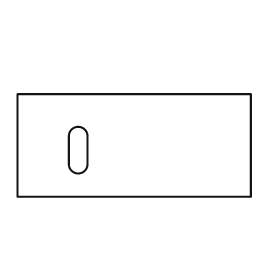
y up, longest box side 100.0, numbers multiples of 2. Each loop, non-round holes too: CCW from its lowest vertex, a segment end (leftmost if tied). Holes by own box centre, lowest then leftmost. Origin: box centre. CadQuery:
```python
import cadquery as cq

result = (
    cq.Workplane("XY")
    .moveTo(-50.0, -22.0)
    .lineTo(50.0, -22.0)
    .lineTo(50.0, 22.0)
    .lineTo(-50.0, 22.0)
    .close()
    .moveTo(-28.0, -8.0)
    .threePointArc((-24.0, -12.0), (-20.0, -8.0))
    .lineTo(-20.0, 4.0)
    .threePointArc((-24.0, 8.0), (-28.0, 4.0))
    .close()
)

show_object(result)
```